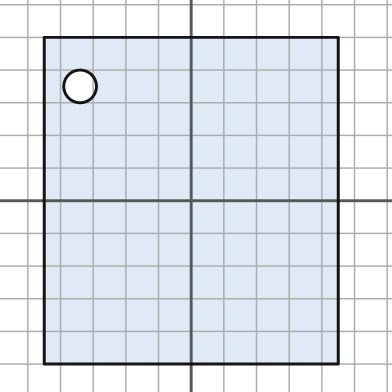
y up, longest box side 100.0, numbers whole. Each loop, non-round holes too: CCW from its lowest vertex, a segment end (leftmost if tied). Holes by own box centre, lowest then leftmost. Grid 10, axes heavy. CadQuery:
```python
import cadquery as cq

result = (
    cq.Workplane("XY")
    .moveTo(-45.0, -50.0)
    .lineTo(45.0, -50.0)
    .lineTo(45.0, 50.0)
    .lineTo(-45.0, 50.0)
    .close()
    .moveTo(-34.0, 35.0)
    .circle(5.0)
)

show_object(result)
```